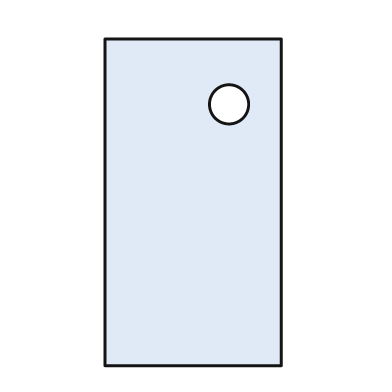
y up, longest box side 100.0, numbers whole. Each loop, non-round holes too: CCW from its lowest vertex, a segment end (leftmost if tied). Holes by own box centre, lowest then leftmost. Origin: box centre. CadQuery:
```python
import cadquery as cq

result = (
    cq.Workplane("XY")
    .moveTo(-27.0, -50.0)
    .lineTo(27.0, -50.0)
    .lineTo(27.0, 50.0)
    .lineTo(-27.0, 50.0)
    .close()
    .moveTo(11.0, 30.0)
    .circle(6.0)
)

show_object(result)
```